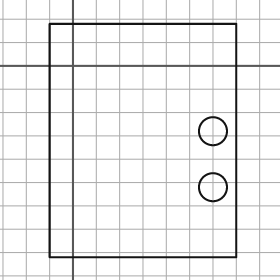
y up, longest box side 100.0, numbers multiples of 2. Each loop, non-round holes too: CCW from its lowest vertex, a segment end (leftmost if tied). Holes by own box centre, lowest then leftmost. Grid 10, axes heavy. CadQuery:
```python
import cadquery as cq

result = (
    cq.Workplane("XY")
    .moveTo(-10.0, -82.0)
    .lineTo(70.0, -82.0)
    .lineTo(70.0, 18.0)
    .lineTo(-10.0, 18.0)
    .close()
    .moveTo(60.0, -52.0)
    .circle(6.0)
    .moveTo(60.0, -28.0)
    .circle(6.0)
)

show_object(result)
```